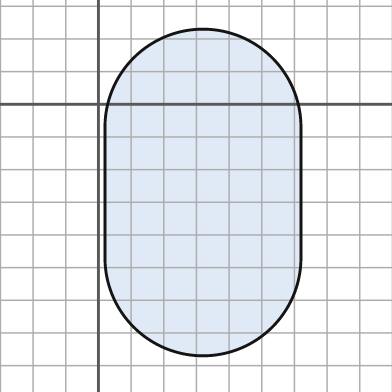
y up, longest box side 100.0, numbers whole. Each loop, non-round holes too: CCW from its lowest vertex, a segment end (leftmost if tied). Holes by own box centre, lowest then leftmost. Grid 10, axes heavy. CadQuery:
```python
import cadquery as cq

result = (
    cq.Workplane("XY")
    .moveTo(2.0, -47.0)
    .threePointArc((32.0, -77.0), (62.0, -47.0))
    .lineTo(62.0, -7.0)
    .threePointArc((32.0, 23.0), (2.0, -7.0))
    .close()
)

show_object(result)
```